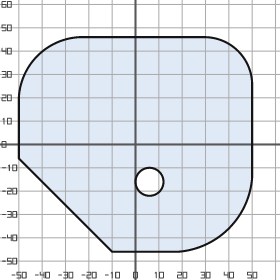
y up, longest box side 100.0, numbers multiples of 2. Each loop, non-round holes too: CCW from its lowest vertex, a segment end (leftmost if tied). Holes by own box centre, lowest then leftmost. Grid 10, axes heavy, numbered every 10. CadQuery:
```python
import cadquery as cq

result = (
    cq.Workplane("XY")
    .moveTo(-10.0, -46.0)
    .lineTo(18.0, -46.0)
    .threePointArc((40.0, -36.0), (50.0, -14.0))
    .lineTo(50.0, 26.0)
    .threePointArc((44.0, 40.0), (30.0, 46.0))
    .lineTo(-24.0, 46.0)
    .threePointArc((-42.0, 38.0), (-50.0, 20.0))
    .lineTo(-50.0, -6.0)
    .close()
    .moveTo(6.0, -16.0)
    .circle(6.0)
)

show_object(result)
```